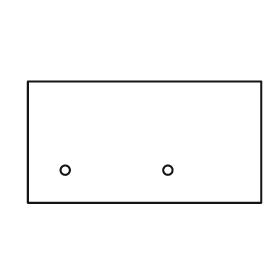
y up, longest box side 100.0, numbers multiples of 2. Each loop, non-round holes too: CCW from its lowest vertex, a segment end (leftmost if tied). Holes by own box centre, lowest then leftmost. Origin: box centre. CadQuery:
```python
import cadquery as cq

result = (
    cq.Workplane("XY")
    .moveTo(-50.0, -26.0)
    .lineTo(50.0, -26.0)
    .lineTo(50.0, 26.0)
    .lineTo(-50.0, 26.0)
    .close()
    .moveTo(-34.0, -12.0)
    .circle(2.0)
    .moveTo(10.0, -12.0)
    .circle(2.0)
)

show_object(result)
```